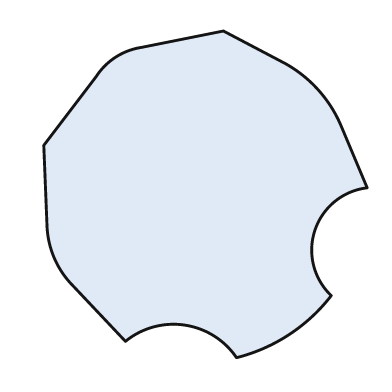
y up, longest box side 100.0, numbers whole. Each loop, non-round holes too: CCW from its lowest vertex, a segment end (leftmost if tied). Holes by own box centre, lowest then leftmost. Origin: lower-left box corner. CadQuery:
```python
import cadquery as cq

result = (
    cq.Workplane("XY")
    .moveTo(59.0, 0.0)
    .threePointArc((75.0, 7.0), (88.0, 19.0))
    .threePointArc((83.0, 39.0), (99.0, 52.0))
    .lineTo(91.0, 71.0)
    .threePointArc((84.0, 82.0), (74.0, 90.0))
    .lineTo(55.0, 100.0)
    .lineTo(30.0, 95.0)
    .threePointArc((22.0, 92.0), (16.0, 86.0))
    .lineTo(0.0, 65.0)
    .lineTo(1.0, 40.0)
    .threePointArc((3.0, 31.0), (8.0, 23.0))
    .lineTo(25.0, 5.0)
    .threePointArc((43.0, 10.0), (59.0, 0.0))
    .close()
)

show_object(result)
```